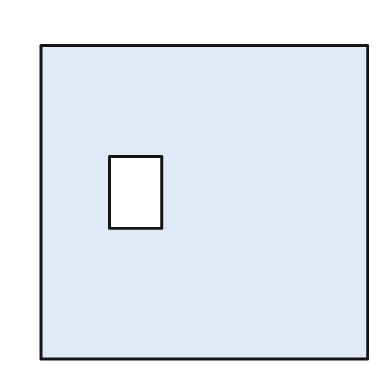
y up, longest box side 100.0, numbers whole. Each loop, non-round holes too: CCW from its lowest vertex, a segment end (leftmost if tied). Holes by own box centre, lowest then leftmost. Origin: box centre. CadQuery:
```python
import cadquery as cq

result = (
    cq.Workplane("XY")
    .moveTo(-50.0, -48.0)
    .lineTo(50.0, -48.0)
    .lineTo(50.0, 48.0)
    .lineTo(-50.0, 48.0)
    .close()
    .moveTo(-29.0, -8.0)
    .lineTo(-13.0, -8.0)
    .lineTo(-13.0, 14.0)
    .lineTo(-29.0, 14.0)
    .close()
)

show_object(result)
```